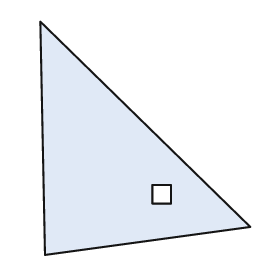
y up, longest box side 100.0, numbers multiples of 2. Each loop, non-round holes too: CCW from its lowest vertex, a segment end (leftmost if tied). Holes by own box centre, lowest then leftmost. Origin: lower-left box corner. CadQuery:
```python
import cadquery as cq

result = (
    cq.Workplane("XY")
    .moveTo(2.0, 0.0)
    .lineTo(90.0, 12.0)
    .lineTo(0.0, 100.0)
    .close()
    .moveTo(48.0, 22.0)
    .lineTo(56.0, 22.0)
    .lineTo(56.0, 30.0)
    .lineTo(48.0, 30.0)
    .close()
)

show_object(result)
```